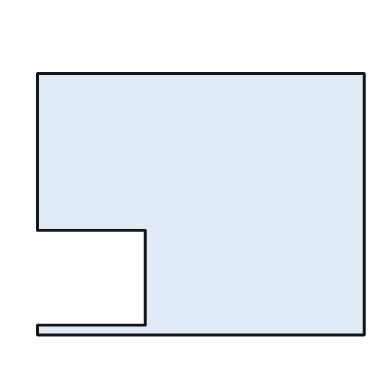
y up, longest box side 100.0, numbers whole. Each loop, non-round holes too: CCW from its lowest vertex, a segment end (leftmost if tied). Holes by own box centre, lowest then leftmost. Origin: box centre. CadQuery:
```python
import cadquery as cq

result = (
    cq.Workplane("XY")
    .moveTo(-50.0, -40.0)
    .lineTo(50.0, -40.0)
    .lineTo(50.0, 40.0)
    .lineTo(-50.0, 40.0)
    .lineTo(-50.0, -8.0)
    .lineTo(-17.0, -8.0)
    .lineTo(-17.0, -37.0)
    .lineTo(-50.0, -37.0)
    .close()
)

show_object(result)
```